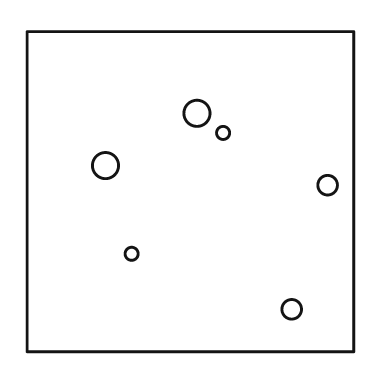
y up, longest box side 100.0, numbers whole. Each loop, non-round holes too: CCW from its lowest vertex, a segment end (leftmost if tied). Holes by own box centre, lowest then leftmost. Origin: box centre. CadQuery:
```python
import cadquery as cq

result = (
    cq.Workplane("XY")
    .moveTo(-50.0, -49.0)
    .lineTo(50.0, -49.0)
    .lineTo(50.0, 49.0)
    .lineTo(-50.0, 49.0)
    .close()
    .moveTo(31.0, -36.0)
    .circle(3.0)
    .moveTo(-18.0, -19.0)
    .circle(2.0)
    .moveTo(42.0, 2.0)
    .circle(3.0)
    .moveTo(-26.0, 8.0)
    .circle(4.0)
    .moveTo(10.0, 18.0)
    .circle(2.0)
    .moveTo(2.0, 24.0)
    .circle(4.0)
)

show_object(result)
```